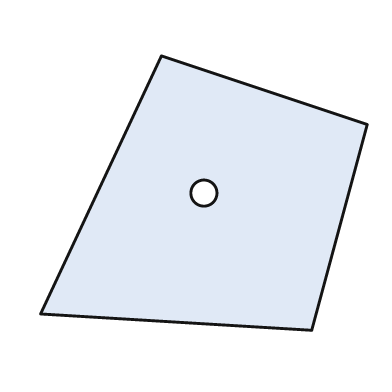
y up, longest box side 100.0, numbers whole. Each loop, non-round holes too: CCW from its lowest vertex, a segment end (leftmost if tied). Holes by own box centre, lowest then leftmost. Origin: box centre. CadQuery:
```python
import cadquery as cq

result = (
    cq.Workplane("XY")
    .moveTo(33.0, -42.0)
    .lineTo(50.0, 21.0)
    .lineTo(-13.0, 42.0)
    .lineTo(-50.0, -37.0)
    .close()
    .moveTo(0.0, 0.0)
    .circle(4.0)
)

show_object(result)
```